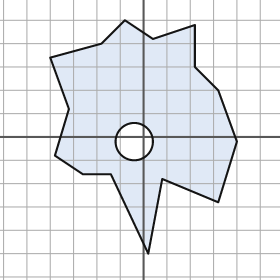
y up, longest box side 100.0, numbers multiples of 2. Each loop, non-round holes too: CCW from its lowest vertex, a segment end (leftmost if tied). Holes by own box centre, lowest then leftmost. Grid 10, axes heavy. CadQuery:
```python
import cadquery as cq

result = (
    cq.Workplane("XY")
    .moveTo(2.0, -50.0)
    .lineTo(8.0, -18.0)
    .lineTo(32.0, -28.0)
    .lineTo(40.0, -2.0)
    .lineTo(32.0, 20.0)
    .lineTo(22.0, 30.0)
    .lineTo(22.0, 48.0)
    .lineTo(4.0, 42.0)
    .lineTo(-8.0, 50.0)
    .lineTo(-18.0, 40.0)
    .lineTo(-40.0, 34.0)
    .lineTo(-32.0, 12.0)
    .lineTo(-38.0, -8.0)
    .lineTo(-26.0, -16.0)
    .lineTo(-14.0, -16.0)
    .close()
    .moveTo(-4.0, -2.0)
    .circle(8.0)
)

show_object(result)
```